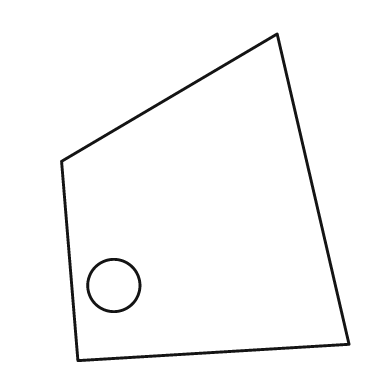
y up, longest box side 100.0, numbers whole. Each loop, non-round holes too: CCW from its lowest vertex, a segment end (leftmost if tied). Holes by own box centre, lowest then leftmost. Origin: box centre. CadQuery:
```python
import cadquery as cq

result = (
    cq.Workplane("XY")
    .moveTo(-39.0, -50.0)
    .lineTo(44.0, -45.0)
    .lineTo(22.0, 50.0)
    .lineTo(-44.0, 11.0)
    .close()
    .moveTo(-28.0, -27.0)
    .circle(8.0)
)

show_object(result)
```